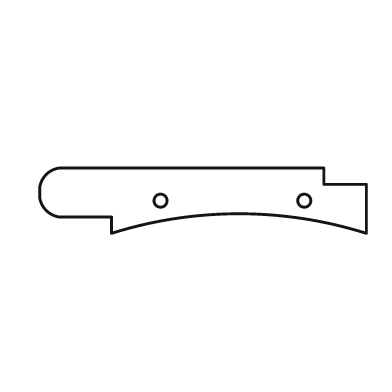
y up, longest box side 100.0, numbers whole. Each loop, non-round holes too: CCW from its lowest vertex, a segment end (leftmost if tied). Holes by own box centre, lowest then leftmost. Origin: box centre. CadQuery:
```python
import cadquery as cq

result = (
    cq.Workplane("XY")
    .moveTo(-28.0, -10.0)
    .threePointArc((11.0, -4.0), (50.0, -10.0))
    .lineTo(50.0, 5.0)
    .lineTo(37.0, 5.0)
    .lineTo(37.0, 10.0)
    .lineTo(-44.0, 10.0)
    .threePointArc((-48.0, 8.0), (-50.0, 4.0))
    .lineTo(-50.0, 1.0)
    .threePointArc((-48.0, -3.0), (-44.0, -5.0))
    .lineTo(-28.0, -5.0)
    .close()
    .moveTo(-13.0, 0.0)
    .circle(2.0)
    .moveTo(31.0, 0.0)
    .circle(2.0)
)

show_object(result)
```